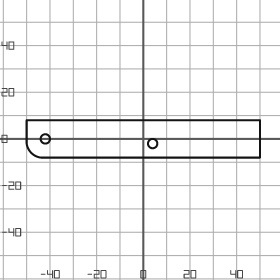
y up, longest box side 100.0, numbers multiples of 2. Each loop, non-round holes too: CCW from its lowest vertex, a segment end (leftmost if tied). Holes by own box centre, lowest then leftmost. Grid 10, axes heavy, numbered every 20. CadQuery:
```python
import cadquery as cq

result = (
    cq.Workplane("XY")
    .moveTo(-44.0, -8.0)
    .lineTo(50.0, -8.0)
    .lineTo(50.0, 8.0)
    .lineTo(-50.0, 8.0)
    .lineTo(-50.0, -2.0)
    .threePointArc((-48.0, -6.0), (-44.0, -8.0))
    .close()
    .moveTo(4.0, -2.0)
    .circle(2.0)
    .moveTo(-42.0, 0.0)
    .circle(2.0)
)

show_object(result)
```